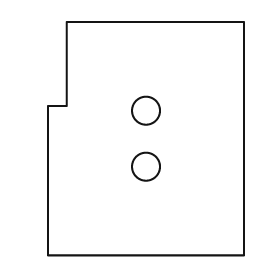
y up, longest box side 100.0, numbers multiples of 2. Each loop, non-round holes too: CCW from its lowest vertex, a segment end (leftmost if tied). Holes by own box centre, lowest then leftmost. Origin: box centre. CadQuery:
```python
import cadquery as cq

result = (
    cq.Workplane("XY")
    .moveTo(-42.0, -50.0)
    .lineTo(42.0, -50.0)
    .lineTo(42.0, 50.0)
    .lineTo(-34.0, 50.0)
    .lineTo(-34.0, 14.0)
    .lineTo(-42.0, 14.0)
    .close()
    .moveTo(0.0, -12.0)
    .circle(6.0)
    .moveTo(0.0, 12.0)
    .circle(6.0)
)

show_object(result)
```